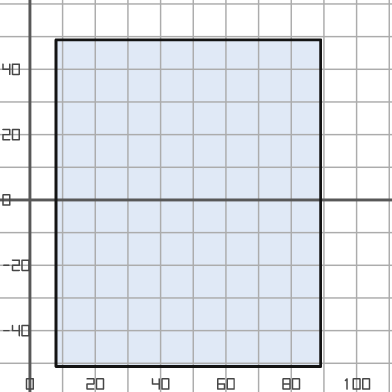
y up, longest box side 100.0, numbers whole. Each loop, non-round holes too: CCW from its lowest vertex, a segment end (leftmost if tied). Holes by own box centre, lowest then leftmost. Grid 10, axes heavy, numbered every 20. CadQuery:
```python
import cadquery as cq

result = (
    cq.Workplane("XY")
    .moveTo(8.0, -51.0)
    .lineTo(89.0, -51.0)
    .lineTo(89.0, 49.0)
    .lineTo(8.0, 49.0)
    .close()
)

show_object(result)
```